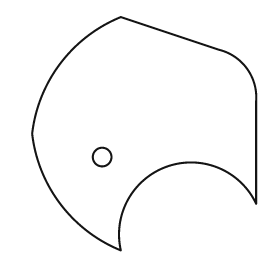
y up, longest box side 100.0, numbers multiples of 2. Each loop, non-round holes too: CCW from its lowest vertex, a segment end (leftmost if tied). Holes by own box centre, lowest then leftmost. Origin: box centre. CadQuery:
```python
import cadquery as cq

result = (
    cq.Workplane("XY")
    .moveTo(-10.0, -50.0)
    .threePointArc((10.0, -14.0), (48.0, -30.0))
    .lineTo(48.0, 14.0)
    .threePointArc((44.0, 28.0), (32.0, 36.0))
    .lineTo(-10.0, 50.0)
    .threePointArc((-36.0, 30.0), (-48.0, 0.0))
    .threePointArc((-36.0, -30.0), (-10.0, -50.0))
    .close()
    .moveTo(-18.0, -10.0)
    .circle(4.0)
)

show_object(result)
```